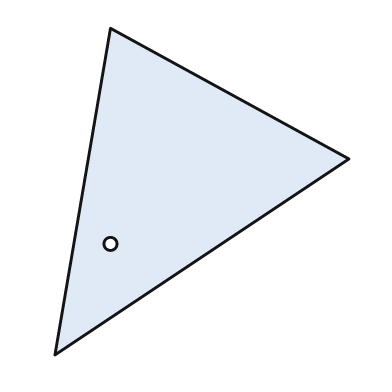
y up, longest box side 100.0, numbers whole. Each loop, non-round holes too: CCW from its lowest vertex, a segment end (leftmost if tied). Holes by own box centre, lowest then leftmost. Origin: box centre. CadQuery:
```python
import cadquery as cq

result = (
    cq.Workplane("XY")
    .moveTo(-45.0, -50.0)
    .lineTo(45.0, 10.0)
    .lineTo(-28.0, 50.0)
    .close()
    .moveTo(-28.0, -16.0)
    .circle(2.0)
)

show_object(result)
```